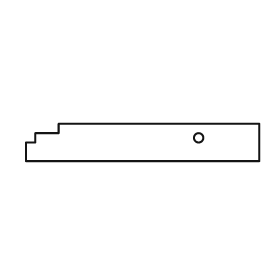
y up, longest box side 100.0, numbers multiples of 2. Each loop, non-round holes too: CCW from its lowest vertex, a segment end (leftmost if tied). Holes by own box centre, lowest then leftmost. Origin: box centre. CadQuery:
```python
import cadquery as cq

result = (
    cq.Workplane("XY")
    .moveTo(-50.0, -8.0)
    .lineTo(50.0, -8.0)
    .lineTo(50.0, 8.0)
    .lineTo(-36.0, 8.0)
    .lineTo(-36.0, 4.0)
    .lineTo(-46.0, 4.0)
    .lineTo(-46.0, 0.0)
    .lineTo(-50.0, 0.0)
    .close()
    .moveTo(24.0, 2.0)
    .circle(2.0)
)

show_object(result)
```